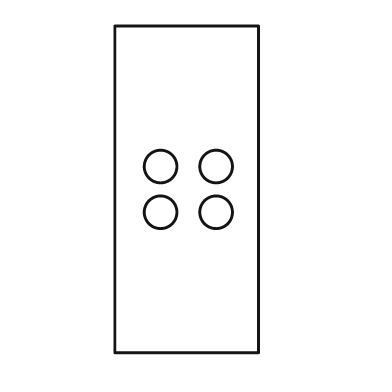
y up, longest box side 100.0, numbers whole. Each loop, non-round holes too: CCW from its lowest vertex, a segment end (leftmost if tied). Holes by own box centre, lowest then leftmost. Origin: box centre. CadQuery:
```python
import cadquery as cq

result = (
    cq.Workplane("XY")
    .moveTo(-22.0, -50.0)
    .lineTo(22.0, -50.0)
    .lineTo(22.0, 50.0)
    .lineTo(-22.0, 50.0)
    .close()
    .moveTo(-8.0, -7.0)
    .circle(5.0)
    .moveTo(9.0, -7.0)
    .circle(5.0)
    .moveTo(-8.0, 7.0)
    .circle(5.0)
    .moveTo(9.0, 7.0)
    .circle(5.0)
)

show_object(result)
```